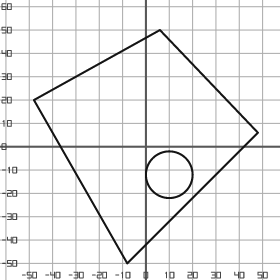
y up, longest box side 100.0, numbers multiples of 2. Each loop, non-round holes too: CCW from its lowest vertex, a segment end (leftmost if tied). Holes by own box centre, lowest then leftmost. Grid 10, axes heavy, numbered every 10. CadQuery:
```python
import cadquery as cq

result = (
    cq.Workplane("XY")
    .moveTo(-8.0, -50.0)
    .lineTo(48.0, 6.0)
    .lineTo(6.0, 50.0)
    .lineTo(-48.0, 20.0)
    .close()
    .moveTo(10.0, -12.0)
    .circle(10.0)
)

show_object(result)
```